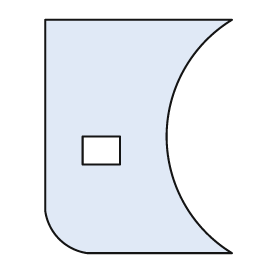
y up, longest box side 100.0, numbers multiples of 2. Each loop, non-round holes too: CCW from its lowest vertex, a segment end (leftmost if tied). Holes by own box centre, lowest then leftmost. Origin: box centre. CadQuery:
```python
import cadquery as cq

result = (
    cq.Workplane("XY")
    .moveTo(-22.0, -50.0)
    .lineTo(40.0, -50.0)
    .threePointArc((12.0, 0.0), (40.0, 50.0))
    .lineTo(-40.0, 50.0)
    .lineTo(-40.0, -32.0)
    .threePointArc((-34.0, -44.0), (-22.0, -50.0))
    .close()
    .moveTo(-24.0, -12.0)
    .lineTo(-8.0, -12.0)
    .lineTo(-8.0, 0.0)
    .lineTo(-24.0, 0.0)
    .close()
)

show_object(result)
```